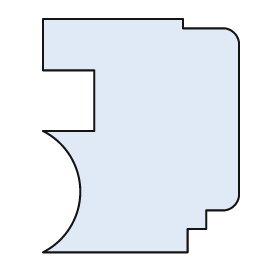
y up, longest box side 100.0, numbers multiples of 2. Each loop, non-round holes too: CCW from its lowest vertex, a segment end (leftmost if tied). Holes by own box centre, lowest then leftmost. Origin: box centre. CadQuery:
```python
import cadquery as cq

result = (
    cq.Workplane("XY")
    .moveTo(-42.0, -50.0)
    .lineTo(20.0, -50.0)
    .lineTo(20.0, -40.0)
    .lineTo(28.0, -40.0)
    .lineTo(28.0, -32.0)
    .lineTo(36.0, -32.0)
    .threePointArc((40.0, -30.0), (42.0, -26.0))
    .lineTo(42.0, 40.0)
    .threePointArc((40.0, 44.0), (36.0, 46.0))
    .lineTo(18.0, 46.0)
    .lineTo(18.0, 50.0)
    .lineTo(-42.0, 50.0)
    .lineTo(-42.0, 28.0)
    .lineTo(-20.0, 28.0)
    .lineTo(-20.0, 2.0)
    .lineTo(-42.0, 2.0)
    .threePointArc((-26.0, -24.0), (-42.0, -50.0))
    .close()
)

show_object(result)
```